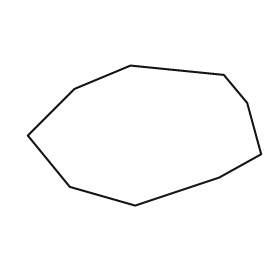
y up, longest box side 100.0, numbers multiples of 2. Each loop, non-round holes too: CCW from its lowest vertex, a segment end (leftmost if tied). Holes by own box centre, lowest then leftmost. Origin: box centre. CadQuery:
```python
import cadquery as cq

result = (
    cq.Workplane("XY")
    .moveTo(-4.0, -30.0)
    .lineTo(32.0, -18.0)
    .lineTo(50.0, -8.0)
    .lineTo(44.0, 14.0)
    .lineTo(34.0, 26.0)
    .lineTo(-6.0, 30.0)
    .lineTo(-30.0, 20.0)
    .lineTo(-50.0, 0.0)
    .lineTo(-32.0, -22.0)
    .close()
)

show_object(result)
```